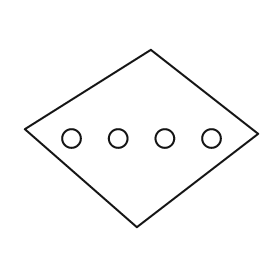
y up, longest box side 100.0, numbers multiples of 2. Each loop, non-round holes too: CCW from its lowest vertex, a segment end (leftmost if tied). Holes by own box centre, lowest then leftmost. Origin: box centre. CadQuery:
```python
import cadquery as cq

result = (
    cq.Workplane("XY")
    .moveTo(-2.0, -38.0)
    .lineTo(50.0, 2.0)
    .lineTo(4.0, 38.0)
    .lineTo(-50.0, 4.0)
    .close()
    .moveTo(-30.0, 0.0)
    .circle(4.0)
    .moveTo(-10.0, 0.0)
    .circle(4.0)
    .moveTo(10.0, 0.0)
    .circle(4.0)
    .moveTo(30.0, 0.0)
    .circle(4.0)
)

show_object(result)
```